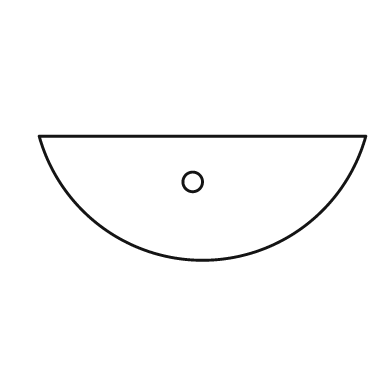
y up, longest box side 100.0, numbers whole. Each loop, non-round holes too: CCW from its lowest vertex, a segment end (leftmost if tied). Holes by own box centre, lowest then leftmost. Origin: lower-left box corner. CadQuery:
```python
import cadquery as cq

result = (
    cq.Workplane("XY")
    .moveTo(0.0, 38.0)
    .threePointArc((50.0, 0.0), (100.0, 38.0))
    .close()
    .moveTo(47.0, 24.0)
    .circle(3.0)
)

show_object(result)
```